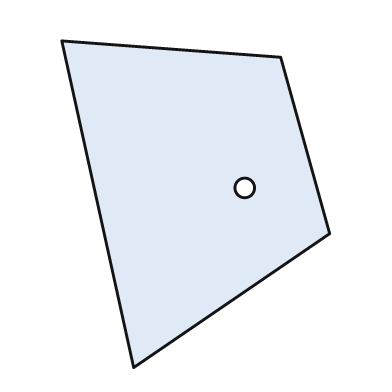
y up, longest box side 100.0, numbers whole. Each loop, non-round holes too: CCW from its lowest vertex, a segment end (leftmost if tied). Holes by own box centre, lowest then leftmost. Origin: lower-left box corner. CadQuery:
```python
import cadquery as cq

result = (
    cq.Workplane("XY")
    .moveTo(22.0, 0.0)
    .lineTo(82.0, 41.0)
    .lineTo(67.0, 95.0)
    .lineTo(0.0, 100.0)
    .close()
    .moveTo(56.0, 55.0)
    .circle(3.0)
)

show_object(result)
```